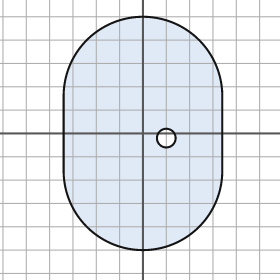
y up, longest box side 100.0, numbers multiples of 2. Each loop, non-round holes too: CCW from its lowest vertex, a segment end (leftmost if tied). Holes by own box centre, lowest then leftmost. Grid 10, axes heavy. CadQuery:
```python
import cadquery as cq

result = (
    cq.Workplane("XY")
    .moveTo(-34.0, -16.0)
    .threePointArc((0.0, -50.0), (34.0, -16.0))
    .lineTo(34.0, 16.0)
    .threePointArc((0.0, 50.0), (-34.0, 16.0))
    .close()
    .moveTo(10.0, -2.0)
    .circle(4.0)
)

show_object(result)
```